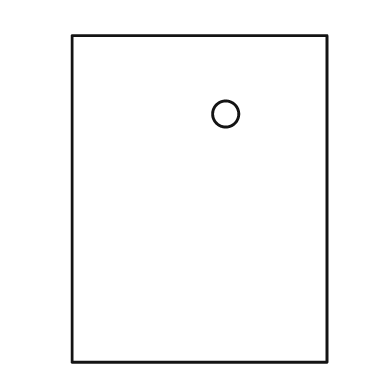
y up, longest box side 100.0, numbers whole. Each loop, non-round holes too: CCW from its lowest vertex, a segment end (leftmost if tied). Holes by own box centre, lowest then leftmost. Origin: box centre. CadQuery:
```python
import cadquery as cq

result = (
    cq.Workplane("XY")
    .moveTo(-39.0, -50.0)
    .lineTo(39.0, -50.0)
    .lineTo(39.0, 50.0)
    .lineTo(-39.0, 50.0)
    .close()
    .moveTo(8.0, 26.0)
    .circle(4.0)
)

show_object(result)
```